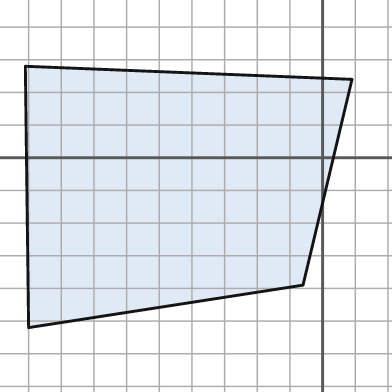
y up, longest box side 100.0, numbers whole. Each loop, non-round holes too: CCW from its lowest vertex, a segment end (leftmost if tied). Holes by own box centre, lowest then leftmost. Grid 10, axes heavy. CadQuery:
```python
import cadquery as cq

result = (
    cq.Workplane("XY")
    .moveTo(-90.0, -52.0)
    .lineTo(-6.0, -39.0)
    .lineTo(9.0, 24.0)
    .lineTo(-91.0, 28.0)
    .close()
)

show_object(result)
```